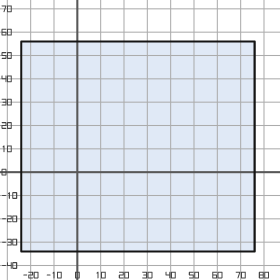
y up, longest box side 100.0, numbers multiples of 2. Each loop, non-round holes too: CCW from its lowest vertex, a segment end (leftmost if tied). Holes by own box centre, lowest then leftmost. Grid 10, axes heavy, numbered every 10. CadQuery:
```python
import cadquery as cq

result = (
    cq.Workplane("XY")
    .moveTo(-24.0, -34.0)
    .lineTo(76.0, -34.0)
    .lineTo(76.0, 56.0)
    .lineTo(-24.0, 56.0)
    .close()
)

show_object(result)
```